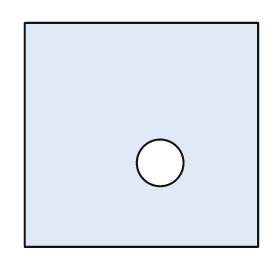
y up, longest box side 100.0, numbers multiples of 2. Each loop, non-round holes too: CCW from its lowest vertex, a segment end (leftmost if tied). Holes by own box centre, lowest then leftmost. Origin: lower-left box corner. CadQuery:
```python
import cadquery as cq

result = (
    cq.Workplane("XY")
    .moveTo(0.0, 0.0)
    .lineTo(100.0, 0.0)
    .lineTo(100.0, 96.0)
    .lineTo(0.0, 96.0)
    .close()
    .moveTo(58.0, 36.0)
    .circle(10.0)
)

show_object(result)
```